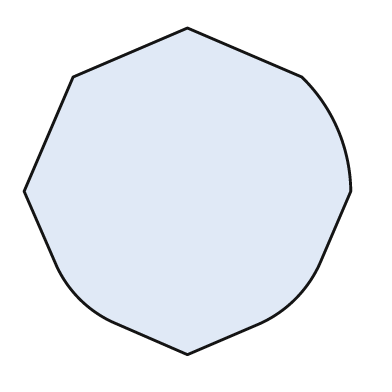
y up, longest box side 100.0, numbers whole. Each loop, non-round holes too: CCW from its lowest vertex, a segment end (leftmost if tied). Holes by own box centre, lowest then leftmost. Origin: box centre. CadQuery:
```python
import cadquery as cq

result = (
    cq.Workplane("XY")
    .moveTo(0.0, -50.0)
    .lineTo(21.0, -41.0)
    .threePointArc((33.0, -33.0), (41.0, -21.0))
    .lineTo(50.0, 0.0)
    .threePointArc((46.0, 19.0), (35.0, 35.0))
    .lineTo(0.0, 50.0)
    .lineTo(-35.0, 35.0)
    .lineTo(-50.0, 0.0)
    .lineTo(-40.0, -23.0)
    .threePointArc((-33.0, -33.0), (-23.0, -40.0))
    .close()
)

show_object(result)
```